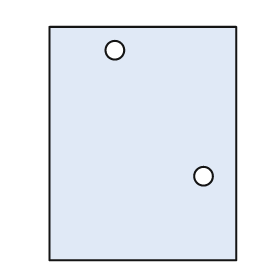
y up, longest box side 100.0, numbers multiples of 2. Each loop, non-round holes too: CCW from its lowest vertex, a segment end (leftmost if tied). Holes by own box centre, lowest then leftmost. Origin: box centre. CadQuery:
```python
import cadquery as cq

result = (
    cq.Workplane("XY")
    .moveTo(-40.0, -50.0)
    .lineTo(40.0, -50.0)
    .lineTo(40.0, 50.0)
    .lineTo(-40.0, 50.0)
    .close()
    .moveTo(26.0, -14.0)
    .circle(4.0)
    .moveTo(-12.0, 40.0)
    .circle(4.0)
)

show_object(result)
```